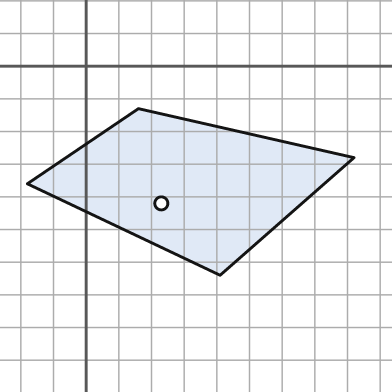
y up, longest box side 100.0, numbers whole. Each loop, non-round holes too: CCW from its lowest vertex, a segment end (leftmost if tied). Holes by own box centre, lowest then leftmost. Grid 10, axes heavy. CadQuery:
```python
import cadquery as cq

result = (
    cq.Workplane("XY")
    .moveTo(41.0, -64.0)
    .lineTo(82.0, -28.0)
    .lineTo(16.0, -13.0)
    .lineTo(-18.0, -36.0)
    .close()
    .moveTo(23.0, -42.0)
    .circle(2.0)
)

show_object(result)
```